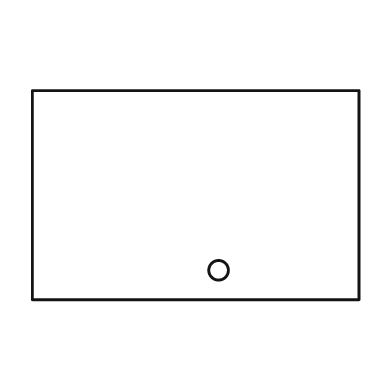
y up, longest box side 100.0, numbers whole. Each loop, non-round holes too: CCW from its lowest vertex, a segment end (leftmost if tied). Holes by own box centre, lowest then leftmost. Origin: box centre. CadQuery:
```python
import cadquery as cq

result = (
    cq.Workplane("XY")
    .moveTo(-50.0, -32.0)
    .lineTo(50.0, -32.0)
    .lineTo(50.0, 32.0)
    .lineTo(-50.0, 32.0)
    .close()
    .moveTo(7.0, -23.0)
    .circle(3.0)
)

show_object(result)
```